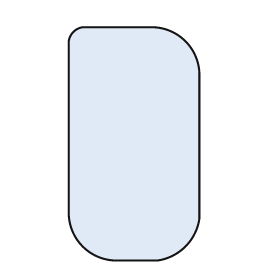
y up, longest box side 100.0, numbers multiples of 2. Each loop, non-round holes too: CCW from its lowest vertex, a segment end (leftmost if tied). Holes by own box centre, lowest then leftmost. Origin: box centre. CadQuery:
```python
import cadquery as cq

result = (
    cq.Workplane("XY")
    .moveTo(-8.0, -50.0)
    .lineTo(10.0, -50.0)
    .threePointArc((22.0, -44.0), (28.0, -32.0))
    .lineTo(28.0, 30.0)
    .threePointArc((22.0, 44.0), (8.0, 50.0))
    .lineTo(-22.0, 50.0)
    .threePointArc((-26.0, 48.0), (-28.0, 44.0))
    .lineTo(-28.0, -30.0)
    .threePointArc((-22.0, -44.0), (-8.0, -50.0))
    .close()
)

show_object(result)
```